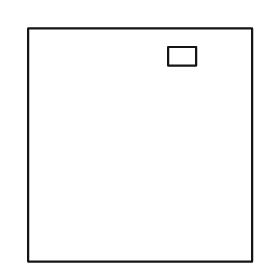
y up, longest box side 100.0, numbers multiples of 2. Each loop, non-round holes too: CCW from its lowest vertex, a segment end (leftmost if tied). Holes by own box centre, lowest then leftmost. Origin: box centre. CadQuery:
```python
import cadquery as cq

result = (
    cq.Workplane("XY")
    .moveTo(-48.0, -50.0)
    .lineTo(48.0, -50.0)
    .lineTo(48.0, 50.0)
    .lineTo(-48.0, 50.0)
    .close()
    .moveTo(12.0, 34.0)
    .lineTo(24.0, 34.0)
    .lineTo(24.0, 42.0)
    .lineTo(12.0, 42.0)
    .close()
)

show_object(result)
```